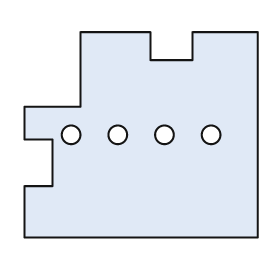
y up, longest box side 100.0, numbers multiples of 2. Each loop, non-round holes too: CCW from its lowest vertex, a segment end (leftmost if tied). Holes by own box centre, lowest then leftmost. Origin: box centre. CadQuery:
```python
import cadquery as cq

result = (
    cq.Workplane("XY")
    .moveTo(-50.0, -44.0)
    .lineTo(50.0, -44.0)
    .lineTo(50.0, 44.0)
    .lineTo(22.0, 44.0)
    .lineTo(22.0, 32.0)
    .lineTo(4.0, 32.0)
    .lineTo(4.0, 44.0)
    .lineTo(-26.0, 44.0)
    .lineTo(-26.0, 12.0)
    .lineTo(-50.0, 12.0)
    .lineTo(-50.0, -2.0)
    .lineTo(-38.0, -2.0)
    .lineTo(-38.0, -22.0)
    .lineTo(-50.0, -22.0)
    .close()
    .moveTo(-30.0, 0.0)
    .circle(4.0)
    .moveTo(-10.0, 0.0)
    .circle(4.0)
    .moveTo(10.0, 0.0)
    .circle(4.0)
    .moveTo(30.0, 0.0)
    .circle(4.0)
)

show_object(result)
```